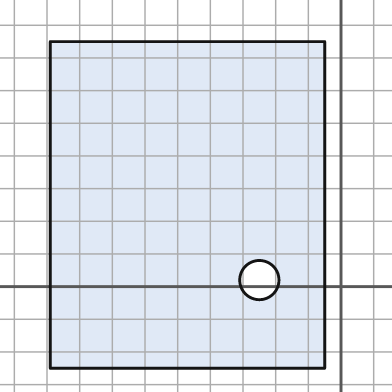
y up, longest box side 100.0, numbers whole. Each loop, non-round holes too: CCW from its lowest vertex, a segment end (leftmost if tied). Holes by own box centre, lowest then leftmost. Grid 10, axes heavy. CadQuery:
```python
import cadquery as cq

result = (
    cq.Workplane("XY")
    .moveTo(-89.0, -25.0)
    .lineTo(-5.0, -25.0)
    .lineTo(-5.0, 75.0)
    .lineTo(-89.0, 75.0)
    .close()
    .moveTo(-25.0, 2.0)
    .circle(6.0)
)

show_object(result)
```